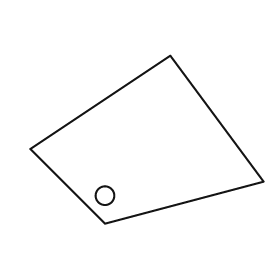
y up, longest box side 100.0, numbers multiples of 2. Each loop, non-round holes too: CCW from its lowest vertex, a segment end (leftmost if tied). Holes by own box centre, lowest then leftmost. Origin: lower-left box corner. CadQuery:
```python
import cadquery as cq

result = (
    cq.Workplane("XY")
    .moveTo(32.0, 0.0)
    .lineTo(100.0, 18.0)
    .lineTo(60.0, 72.0)
    .lineTo(0.0, 32.0)
    .close()
    .moveTo(32.0, 12.0)
    .circle(4.0)
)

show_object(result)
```